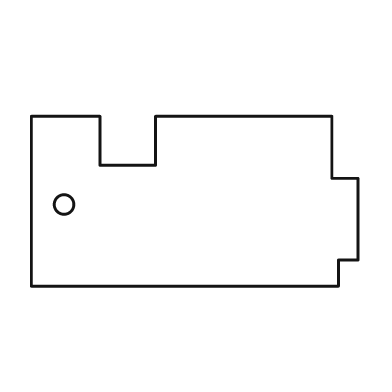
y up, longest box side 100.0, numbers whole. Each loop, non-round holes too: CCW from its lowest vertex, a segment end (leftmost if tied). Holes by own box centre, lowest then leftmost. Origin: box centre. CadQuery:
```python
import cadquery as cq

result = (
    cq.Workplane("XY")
    .moveTo(-50.0, -26.0)
    .lineTo(44.0, -26.0)
    .lineTo(44.0, -18.0)
    .lineTo(50.0, -18.0)
    .lineTo(50.0, 7.0)
    .lineTo(42.0, 7.0)
    .lineTo(42.0, 26.0)
    .lineTo(-12.0, 26.0)
    .lineTo(-12.0, 11.0)
    .lineTo(-29.0, 11.0)
    .lineTo(-29.0, 26.0)
    .lineTo(-50.0, 26.0)
    .close()
    .moveTo(-40.0, -1.0)
    .circle(3.0)
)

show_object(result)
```